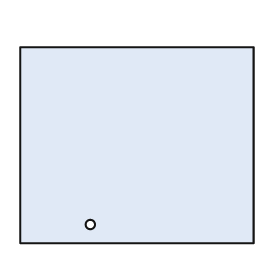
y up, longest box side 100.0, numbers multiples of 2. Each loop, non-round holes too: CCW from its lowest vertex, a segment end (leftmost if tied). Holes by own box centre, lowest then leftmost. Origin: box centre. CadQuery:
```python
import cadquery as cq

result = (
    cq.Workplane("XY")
    .moveTo(-50.0, -42.0)
    .lineTo(50.0, -42.0)
    .lineTo(50.0, 42.0)
    .lineTo(-50.0, 42.0)
    .close()
    .moveTo(-20.0, -34.0)
    .circle(2.0)
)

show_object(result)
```